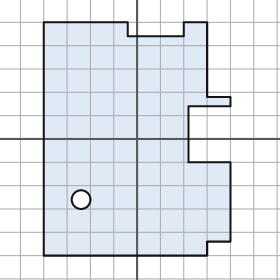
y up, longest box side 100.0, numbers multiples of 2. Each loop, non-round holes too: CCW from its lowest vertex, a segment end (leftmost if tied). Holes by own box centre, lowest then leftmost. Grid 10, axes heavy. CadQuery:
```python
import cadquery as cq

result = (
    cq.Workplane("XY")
    .moveTo(-40.0, -50.0)
    .lineTo(30.0, -50.0)
    .lineTo(30.0, -44.0)
    .lineTo(40.0, -44.0)
    .lineTo(40.0, -10.0)
    .lineTo(22.0, -10.0)
    .lineTo(22.0, 14.0)
    .lineTo(40.0, 14.0)
    .lineTo(40.0, 18.0)
    .lineTo(30.0, 18.0)
    .lineTo(30.0, 50.0)
    .lineTo(20.0, 50.0)
    .lineTo(20.0, 44.0)
    .lineTo(-4.0, 44.0)
    .lineTo(-4.0, 50.0)
    .lineTo(-40.0, 50.0)
    .close()
    .moveTo(-24.0, -26.0)
    .circle(4.0)
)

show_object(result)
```